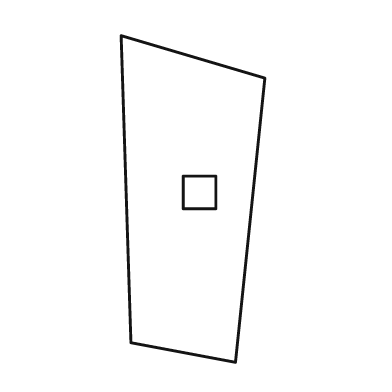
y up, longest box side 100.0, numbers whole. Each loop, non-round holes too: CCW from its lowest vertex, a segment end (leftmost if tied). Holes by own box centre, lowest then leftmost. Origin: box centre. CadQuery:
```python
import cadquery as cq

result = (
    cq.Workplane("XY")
    .moveTo(13.0, -50.0)
    .lineTo(22.0, 37.0)
    .lineTo(-22.0, 50.0)
    .lineTo(-19.0, -44.0)
    .close()
    .moveTo(-3.0, -3.0)
    .lineTo(7.0, -3.0)
    .lineTo(7.0, 7.0)
    .lineTo(-3.0, 7.0)
    .close()
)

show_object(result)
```